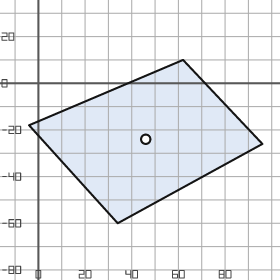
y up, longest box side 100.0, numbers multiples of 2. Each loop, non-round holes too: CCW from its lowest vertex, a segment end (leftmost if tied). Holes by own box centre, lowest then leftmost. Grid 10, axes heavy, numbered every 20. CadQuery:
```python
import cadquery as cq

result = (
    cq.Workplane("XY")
    .moveTo(34.0, -60.0)
    .lineTo(96.0, -26.0)
    .lineTo(62.0, 10.0)
    .lineTo(-4.0, -18.0)
    .close()
    .moveTo(46.0, -24.0)
    .circle(2.0)
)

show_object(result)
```